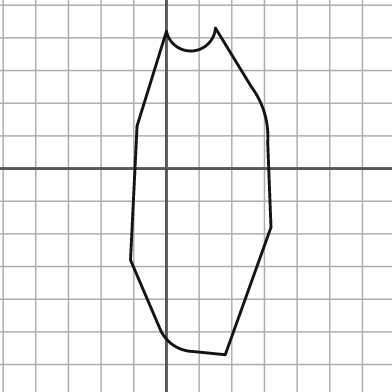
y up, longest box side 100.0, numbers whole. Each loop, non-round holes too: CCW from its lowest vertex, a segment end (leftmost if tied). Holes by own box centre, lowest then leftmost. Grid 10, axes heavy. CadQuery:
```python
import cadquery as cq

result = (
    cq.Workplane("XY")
    .moveTo(18.0, -57.0)
    .lineTo(32.0, -18.0)
    .lineTo(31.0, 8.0)
    .threePointArc((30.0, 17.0), (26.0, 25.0))
    .lineTo(15.0, 43.0)
    .threePointArc((8.0, 36.0), (0.0, 42.0))
    .lineTo(-9.0, 13.0)
    .lineTo(-11.0, -28.0)
    .lineTo(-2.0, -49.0)
    .threePointArc((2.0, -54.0), (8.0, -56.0))
    .close()
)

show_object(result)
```